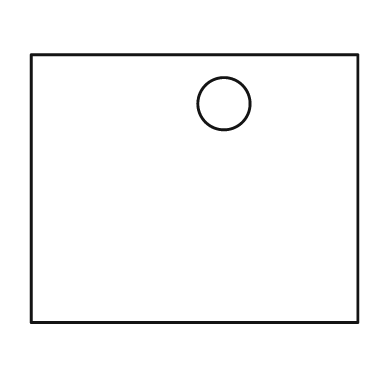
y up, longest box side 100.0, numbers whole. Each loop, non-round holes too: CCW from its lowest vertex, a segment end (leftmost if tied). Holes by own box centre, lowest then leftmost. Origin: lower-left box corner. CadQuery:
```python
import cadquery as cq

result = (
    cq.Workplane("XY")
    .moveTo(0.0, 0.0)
    .lineTo(100.0, 0.0)
    .lineTo(100.0, 82.0)
    .lineTo(0.0, 82.0)
    .close()
    .moveTo(59.0, 67.0)
    .circle(8.0)
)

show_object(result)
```